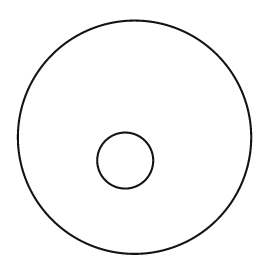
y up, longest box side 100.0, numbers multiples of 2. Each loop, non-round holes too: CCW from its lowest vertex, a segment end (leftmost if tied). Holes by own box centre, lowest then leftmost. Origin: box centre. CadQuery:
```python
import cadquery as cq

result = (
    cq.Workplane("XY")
    .moveTo(0.0, 0.0)
    .circle(50.0)
    .moveTo(-4.0, -10.0)
    .circle(12.0)
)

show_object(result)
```